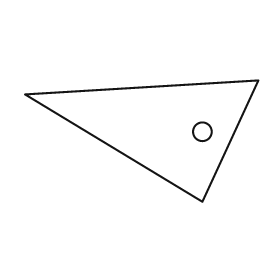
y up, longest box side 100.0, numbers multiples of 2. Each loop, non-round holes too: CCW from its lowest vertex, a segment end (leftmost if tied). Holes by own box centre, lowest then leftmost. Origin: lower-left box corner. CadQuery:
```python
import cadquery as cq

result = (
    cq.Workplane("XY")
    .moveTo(76.0, 0.0)
    .lineTo(100.0, 52.0)
    .lineTo(0.0, 46.0)
    .close()
    .moveTo(76.0, 30.0)
    .circle(4.0)
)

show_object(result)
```